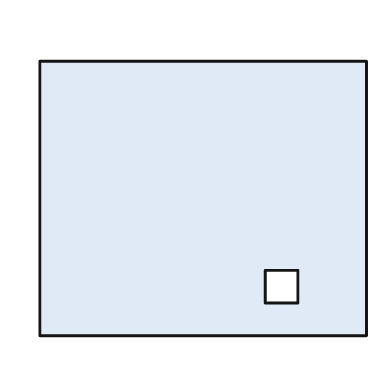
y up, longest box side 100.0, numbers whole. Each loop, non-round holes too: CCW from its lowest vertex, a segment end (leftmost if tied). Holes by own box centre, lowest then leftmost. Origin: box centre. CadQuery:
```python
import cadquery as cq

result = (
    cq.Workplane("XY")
    .moveTo(-50.0, -42.0)
    .lineTo(50.0, -42.0)
    .lineTo(50.0, 42.0)
    .lineTo(-50.0, 42.0)
    .close()
    .moveTo(19.0, -32.0)
    .lineTo(29.0, -32.0)
    .lineTo(29.0, -22.0)
    .lineTo(19.0, -22.0)
    .close()
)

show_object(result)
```